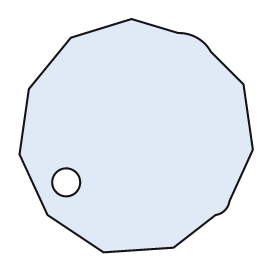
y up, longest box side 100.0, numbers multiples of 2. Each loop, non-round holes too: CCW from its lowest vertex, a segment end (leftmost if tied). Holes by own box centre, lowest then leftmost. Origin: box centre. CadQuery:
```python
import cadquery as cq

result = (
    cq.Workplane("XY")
    .moveTo(-14.0, -50.0)
    .lineTo(16.0, -48.0)
    .lineTo(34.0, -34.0)
    .threePointArc((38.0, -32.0), (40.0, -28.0))
    .lineTo(50.0, -6.0)
    .lineTo(46.0, 22.0)
    .lineTo(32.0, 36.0)
    .threePointArc((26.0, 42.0), (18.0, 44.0))
    .lineTo(-2.0, 50.0)
    .lineTo(-28.0, 42.0)
    .lineTo(-46.0, 20.0)
    .lineTo(-50.0, -8.0)
    .lineTo(-38.0, -34.0)
    .close()
    .moveTo(-30.0, -20.0)
    .circle(6.0)
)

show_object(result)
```